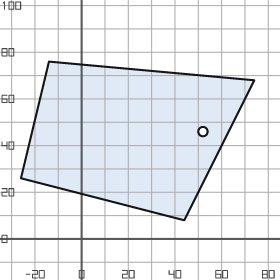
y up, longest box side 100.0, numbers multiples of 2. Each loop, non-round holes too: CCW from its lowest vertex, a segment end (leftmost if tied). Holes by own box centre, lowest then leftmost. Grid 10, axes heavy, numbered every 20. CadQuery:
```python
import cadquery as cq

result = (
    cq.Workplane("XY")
    .moveTo(44.0, 8.0)
    .lineTo(74.0, 68.0)
    .lineTo(-14.0, 76.0)
    .lineTo(-26.0, 26.0)
    .close()
    .moveTo(52.0, 46.0)
    .circle(2.0)
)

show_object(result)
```